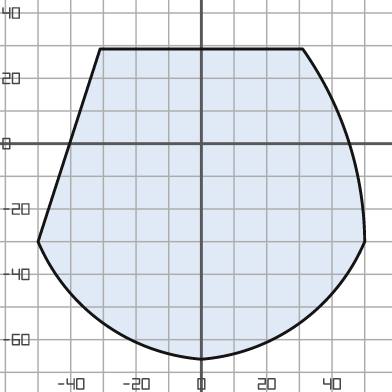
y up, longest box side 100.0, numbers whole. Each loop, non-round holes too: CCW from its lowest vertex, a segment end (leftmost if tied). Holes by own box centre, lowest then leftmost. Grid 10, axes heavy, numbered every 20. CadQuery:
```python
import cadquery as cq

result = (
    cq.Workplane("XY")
    .moveTo(0.0, -66.0)
    .threePointArc((30.0, -55.0), (50.0, -30.0))
    .threePointArc((45.0, 1.0), (31.0, 29.0))
    .lineTo(-31.0, 29.0)
    .lineTo(-50.0, -30.0)
    .threePointArc((-30.0, -55.0), (0.0, -66.0))
    .close()
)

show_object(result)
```